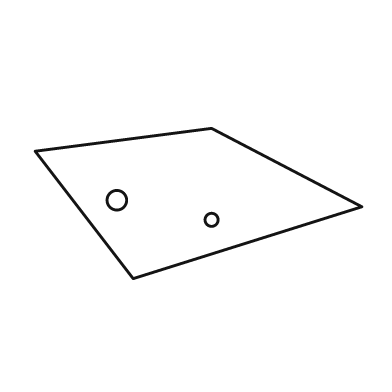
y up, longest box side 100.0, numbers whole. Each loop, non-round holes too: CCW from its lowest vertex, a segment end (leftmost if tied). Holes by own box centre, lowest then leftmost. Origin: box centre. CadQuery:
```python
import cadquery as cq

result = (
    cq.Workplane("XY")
    .moveTo(-20.0, -23.0)
    .lineTo(50.0, -1.0)
    .lineTo(4.0, 23.0)
    .lineTo(-50.0, 16.0)
    .close()
    .moveTo(4.0, -5.0)
    .circle(2.0)
    .moveTo(-25.0, 1.0)
    .circle(3.0)
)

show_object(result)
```